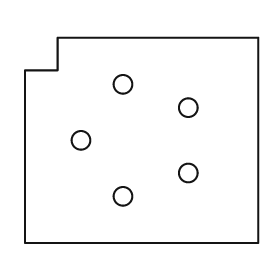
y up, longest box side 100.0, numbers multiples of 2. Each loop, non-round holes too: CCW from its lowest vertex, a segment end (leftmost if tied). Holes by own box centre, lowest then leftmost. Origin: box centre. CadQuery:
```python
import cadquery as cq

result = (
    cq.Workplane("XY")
    .moveTo(-50.0, -44.0)
    .lineTo(50.0, -44.0)
    .lineTo(50.0, 44.0)
    .lineTo(-36.0, 44.0)
    .lineTo(-36.0, 30.0)
    .lineTo(-50.0, 30.0)
    .close()
    .moveTo(-8.0, -24.0)
    .circle(4.0)
    .moveTo(20.0, -14.0)
    .circle(4.0)
    .moveTo(-26.0, 0.0)
    .circle(4.0)
    .moveTo(20.0, 14.0)
    .circle(4.0)
    .moveTo(-8.0, 24.0)
    .circle(4.0)
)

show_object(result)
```